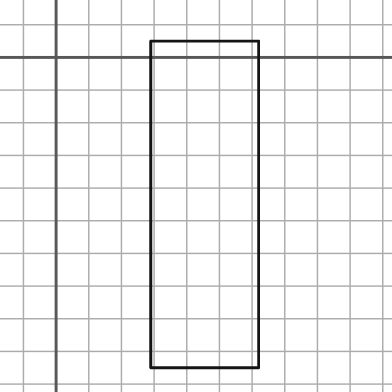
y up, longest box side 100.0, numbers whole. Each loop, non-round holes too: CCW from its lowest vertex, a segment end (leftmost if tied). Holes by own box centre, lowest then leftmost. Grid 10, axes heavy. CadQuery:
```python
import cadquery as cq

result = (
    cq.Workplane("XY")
    .moveTo(29.0, -95.0)
    .lineTo(62.0, -95.0)
    .lineTo(62.0, 5.0)
    .lineTo(29.0, 5.0)
    .close()
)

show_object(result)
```